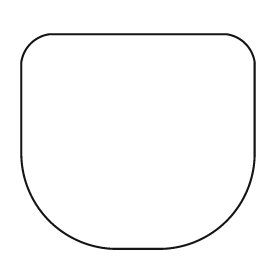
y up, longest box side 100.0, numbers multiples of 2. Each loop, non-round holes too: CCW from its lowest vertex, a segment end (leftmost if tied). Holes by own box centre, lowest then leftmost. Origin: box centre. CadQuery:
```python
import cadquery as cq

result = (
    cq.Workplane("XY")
    .moveTo(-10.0, -46.0)
    .lineTo(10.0, -46.0)
    .threePointArc((38.0, -34.0), (50.0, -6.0))
    .lineTo(50.0, 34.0)
    .threePointArc((46.0, 42.0), (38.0, 46.0))
    .lineTo(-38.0, 46.0)
    .threePointArc((-46.0, 42.0), (-50.0, 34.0))
    .lineTo(-50.0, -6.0)
    .threePointArc((-38.0, -34.0), (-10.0, -46.0))
    .close()
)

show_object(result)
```